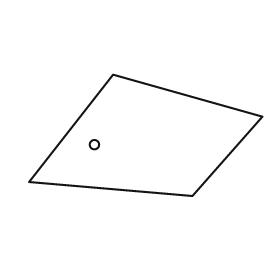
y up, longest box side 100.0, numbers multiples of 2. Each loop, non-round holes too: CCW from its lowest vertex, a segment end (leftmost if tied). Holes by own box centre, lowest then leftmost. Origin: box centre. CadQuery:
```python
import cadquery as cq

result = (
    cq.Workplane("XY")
    .moveTo(20.0, -26.0)
    .lineTo(50.0, 8.0)
    .lineTo(-14.0, 26.0)
    .lineTo(-50.0, -20.0)
    .close()
    .moveTo(-22.0, -4.0)
    .circle(2.0)
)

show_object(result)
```